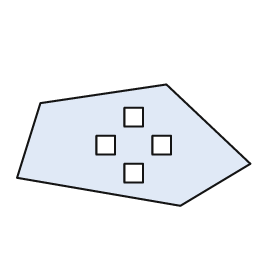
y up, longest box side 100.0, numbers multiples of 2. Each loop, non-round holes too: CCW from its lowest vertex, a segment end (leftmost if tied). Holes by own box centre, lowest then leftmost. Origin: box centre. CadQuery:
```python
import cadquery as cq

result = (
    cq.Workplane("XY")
    .moveTo(20.0, -26.0)
    .lineTo(50.0, -8.0)
    .lineTo(14.0, 26.0)
    .lineTo(-40.0, 18.0)
    .lineTo(-50.0, -14.0)
    .close()
    .moveTo(-4.0, -16.0)
    .lineTo(4.0, -16.0)
    .lineTo(4.0, -8.0)
    .lineTo(-4.0, -8.0)
    .close()
    .moveTo(-16.0, -4.0)
    .lineTo(-8.0, -4.0)
    .lineTo(-8.0, 4.0)
    .lineTo(-16.0, 4.0)
    .close()
    .moveTo(8.0, -4.0)
    .lineTo(16.0, -4.0)
    .lineTo(16.0, 4.0)
    .lineTo(8.0, 4.0)
    .close()
    .moveTo(-4.0, 8.0)
    .lineTo(4.0, 8.0)
    .lineTo(4.0, 16.0)
    .lineTo(-4.0, 16.0)
    .close()
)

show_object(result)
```